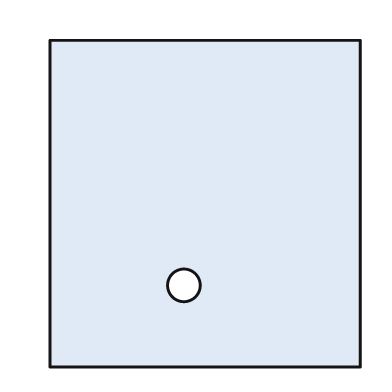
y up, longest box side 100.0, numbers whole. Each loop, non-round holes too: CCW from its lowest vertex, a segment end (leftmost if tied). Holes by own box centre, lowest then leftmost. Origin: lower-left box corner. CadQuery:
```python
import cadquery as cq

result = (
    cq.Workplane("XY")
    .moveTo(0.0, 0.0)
    .lineTo(95.0, 0.0)
    .lineTo(95.0, 100.0)
    .lineTo(0.0, 100.0)
    .close()
    .moveTo(41.0, 25.0)
    .circle(5.0)
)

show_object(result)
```